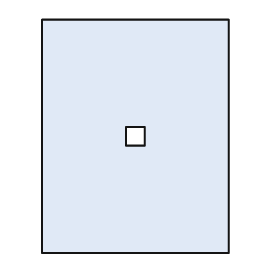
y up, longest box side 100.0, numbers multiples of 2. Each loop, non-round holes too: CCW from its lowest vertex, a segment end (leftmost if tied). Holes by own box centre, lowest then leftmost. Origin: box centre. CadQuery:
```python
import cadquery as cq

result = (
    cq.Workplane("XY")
    .moveTo(-40.0, -50.0)
    .lineTo(40.0, -50.0)
    .lineTo(40.0, 50.0)
    .lineTo(-40.0, 50.0)
    .close()
    .moveTo(-4.0, -4.0)
    .lineTo(4.0, -4.0)
    .lineTo(4.0, 4.0)
    .lineTo(-4.0, 4.0)
    .close()
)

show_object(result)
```